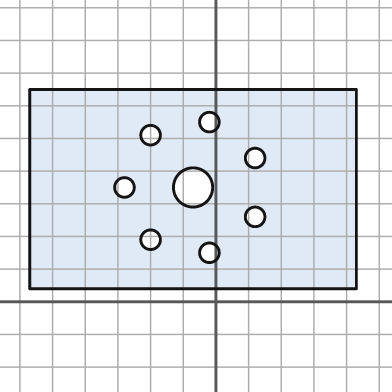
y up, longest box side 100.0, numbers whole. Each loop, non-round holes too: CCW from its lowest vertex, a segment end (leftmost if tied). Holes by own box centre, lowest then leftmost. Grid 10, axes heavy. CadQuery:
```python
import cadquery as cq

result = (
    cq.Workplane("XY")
    .moveTo(-57.0, 4.0)
    .lineTo(43.0, 4.0)
    .lineTo(43.0, 65.0)
    .lineTo(-57.0, 65.0)
    .close()
    .moveTo(-2.0, 15.0)
    .circle(3.0)
    .moveTo(-20.0, 19.0)
    .circle(3.0)
    .moveTo(12.0, 26.0)
    .circle(3.0)
    .moveTo(-28.0, 35.0)
    .circle(3.0)
    .moveTo(-7.0, 35.0)
    .circle(6.0)
    .moveTo(12.0, 44.0)
    .circle(3.0)
    .moveTo(-20.0, 51.0)
    .circle(3.0)
    .moveTo(-2.0, 55.0)
    .circle(3.0)
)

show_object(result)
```